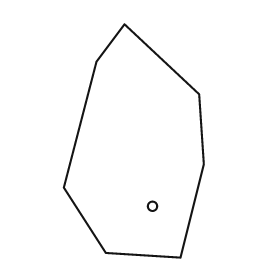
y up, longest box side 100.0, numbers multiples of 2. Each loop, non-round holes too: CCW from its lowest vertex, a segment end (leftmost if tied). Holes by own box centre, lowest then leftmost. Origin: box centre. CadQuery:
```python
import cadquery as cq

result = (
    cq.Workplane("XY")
    .moveTo(20.0, -50.0)
    .lineTo(30.0, -10.0)
    .lineTo(28.0, 20.0)
    .lineTo(-4.0, 50.0)
    .lineTo(-16.0, 34.0)
    .lineTo(-30.0, -20.0)
    .lineTo(-12.0, -48.0)
    .close()
    .moveTo(8.0, -28.0)
    .circle(2.0)
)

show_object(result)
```